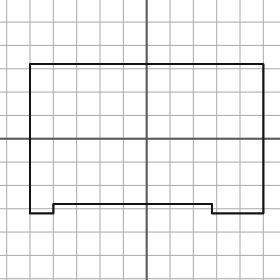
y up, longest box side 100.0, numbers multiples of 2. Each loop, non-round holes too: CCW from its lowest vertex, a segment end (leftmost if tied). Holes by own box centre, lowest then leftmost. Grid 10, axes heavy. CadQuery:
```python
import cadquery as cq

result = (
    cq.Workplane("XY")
    .moveTo(-50.0, -32.0)
    .lineTo(-40.0, -32.0)
    .lineTo(-40.0, -28.0)
    .lineTo(28.0, -28.0)
    .lineTo(28.0, -32.0)
    .lineTo(50.0, -32.0)
    .lineTo(50.0, 32.0)
    .lineTo(-50.0, 32.0)
    .close()
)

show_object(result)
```